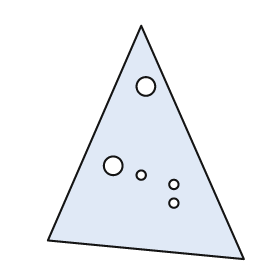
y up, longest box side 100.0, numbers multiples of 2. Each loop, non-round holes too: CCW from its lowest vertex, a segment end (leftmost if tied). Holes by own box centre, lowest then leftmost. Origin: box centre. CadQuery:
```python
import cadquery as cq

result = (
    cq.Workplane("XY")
    .moveTo(42.0, -50.0)
    .lineTo(-2.0, 50.0)
    .lineTo(-42.0, -42.0)
    .close()
    .moveTo(12.0, -26.0)
    .circle(2.0)
    .moveTo(12.0, -18.0)
    .circle(2.0)
    .moveTo(-2.0, -14.0)
    .circle(2.0)
    .moveTo(-14.0, -10.0)
    .circle(4.0)
    .moveTo(0.0, 24.0)
    .circle(4.0)
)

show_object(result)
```